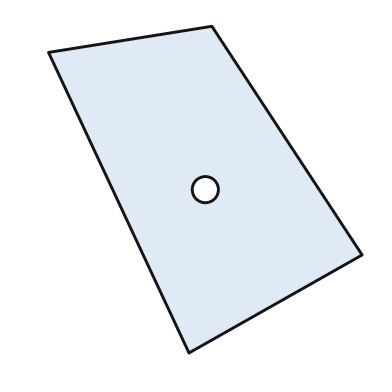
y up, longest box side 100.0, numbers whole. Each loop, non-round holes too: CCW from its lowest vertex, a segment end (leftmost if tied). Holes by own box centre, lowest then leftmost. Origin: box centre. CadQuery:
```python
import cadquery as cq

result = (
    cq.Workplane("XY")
    .moveTo(-5.0, -50.0)
    .lineTo(48.0, -20.0)
    .lineTo(2.0, 50.0)
    .lineTo(-48.0, 42.0)
    .close()
    .moveTo(0.0, 0.0)
    .circle(4.0)
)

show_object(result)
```